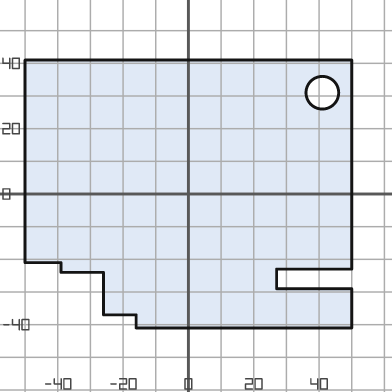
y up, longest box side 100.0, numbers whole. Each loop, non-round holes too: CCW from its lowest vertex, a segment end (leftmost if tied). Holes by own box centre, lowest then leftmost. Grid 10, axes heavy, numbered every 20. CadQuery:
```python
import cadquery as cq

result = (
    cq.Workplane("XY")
    .moveTo(-16.0, -41.0)
    .lineTo(50.0, -41.0)
    .lineTo(50.0, -29.0)
    .lineTo(27.0, -29.0)
    .lineTo(27.0, -23.0)
    .lineTo(50.0, -23.0)
    .lineTo(50.0, 41.0)
    .lineTo(-50.0, 41.0)
    .lineTo(-50.0, -21.0)
    .lineTo(-39.0, -21.0)
    .lineTo(-39.0, -24.0)
    .lineTo(-26.0, -24.0)
    .lineTo(-26.0, -37.0)
    .lineTo(-16.0, -37.0)
    .close()
    .moveTo(41.0, 31.0)
    .circle(5.0)
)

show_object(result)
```